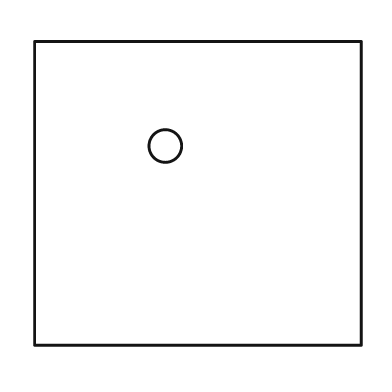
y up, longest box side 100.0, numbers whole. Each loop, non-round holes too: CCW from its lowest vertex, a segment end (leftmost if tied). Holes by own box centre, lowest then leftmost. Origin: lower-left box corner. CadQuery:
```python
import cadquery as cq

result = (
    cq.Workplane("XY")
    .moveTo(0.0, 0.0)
    .lineTo(100.0, 0.0)
    .lineTo(100.0, 93.0)
    .lineTo(0.0, 93.0)
    .close()
    .moveTo(40.0, 61.0)
    .circle(5.0)
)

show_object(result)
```